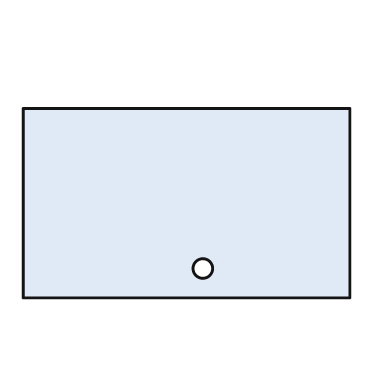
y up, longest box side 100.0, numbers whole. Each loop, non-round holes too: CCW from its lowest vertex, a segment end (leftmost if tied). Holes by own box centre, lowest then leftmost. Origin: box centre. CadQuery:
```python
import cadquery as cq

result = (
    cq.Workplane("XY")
    .moveTo(-50.0, -29.0)
    .lineTo(50.0, -29.0)
    .lineTo(50.0, 29.0)
    .lineTo(-50.0, 29.0)
    .close()
    .moveTo(5.0, -20.0)
    .circle(3.0)
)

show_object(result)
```